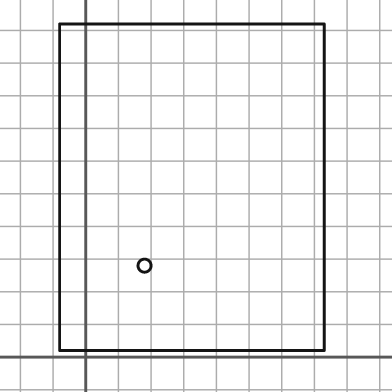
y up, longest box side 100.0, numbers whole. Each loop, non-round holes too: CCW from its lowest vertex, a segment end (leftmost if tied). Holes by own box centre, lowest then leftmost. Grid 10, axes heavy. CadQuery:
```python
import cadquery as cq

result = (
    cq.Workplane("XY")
    .moveTo(-8.0, 2.0)
    .lineTo(73.0, 2.0)
    .lineTo(73.0, 102.0)
    .lineTo(-8.0, 102.0)
    .close()
    .moveTo(18.0, 28.0)
    .circle(2.0)
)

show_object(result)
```